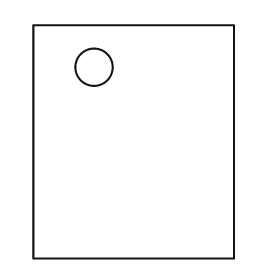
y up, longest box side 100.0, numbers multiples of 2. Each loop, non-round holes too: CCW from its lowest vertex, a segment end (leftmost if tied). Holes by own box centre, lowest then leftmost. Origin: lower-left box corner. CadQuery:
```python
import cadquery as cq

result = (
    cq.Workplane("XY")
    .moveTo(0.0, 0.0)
    .lineTo(86.0, 0.0)
    .lineTo(86.0, 100.0)
    .lineTo(0.0, 100.0)
    .close()
    .moveTo(26.0, 82.0)
    .circle(8.0)
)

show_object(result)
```